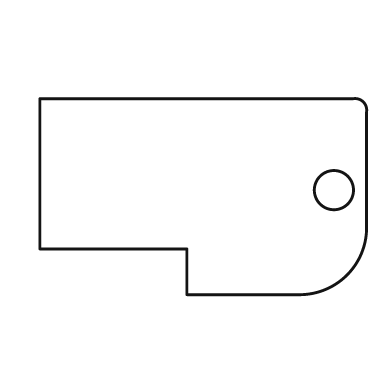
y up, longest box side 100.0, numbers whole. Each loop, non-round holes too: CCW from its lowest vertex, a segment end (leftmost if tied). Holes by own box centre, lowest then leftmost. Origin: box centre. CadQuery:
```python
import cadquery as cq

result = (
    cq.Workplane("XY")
    .moveTo(-5.0, -30.0)
    .lineTo(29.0, -30.0)
    .threePointArc((44.0, -24.0), (50.0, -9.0))
    .lineTo(50.0, 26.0)
    .threePointArc((49.0, 29.0), (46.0, 30.0))
    .lineTo(-50.0, 30.0)
    .lineTo(-50.0, -16.0)
    .lineTo(-5.0, -16.0)
    .close()
    .moveTo(40.0, 2.0)
    .circle(6.0)
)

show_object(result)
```